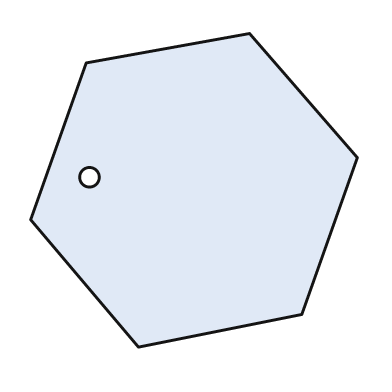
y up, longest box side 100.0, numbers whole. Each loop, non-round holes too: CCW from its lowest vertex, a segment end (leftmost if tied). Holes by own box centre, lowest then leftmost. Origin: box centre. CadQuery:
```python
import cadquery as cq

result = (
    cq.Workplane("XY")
    .moveTo(-17.0, -48.0)
    .lineTo(33.0, -38.0)
    .lineTo(50.0, 10.0)
    .lineTo(17.0, 48.0)
    .lineTo(-33.0, 39.0)
    .lineTo(-50.0, -9.0)
    .close()
    .moveTo(-32.0, 4.0)
    .circle(3.0)
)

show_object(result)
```